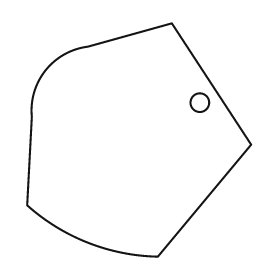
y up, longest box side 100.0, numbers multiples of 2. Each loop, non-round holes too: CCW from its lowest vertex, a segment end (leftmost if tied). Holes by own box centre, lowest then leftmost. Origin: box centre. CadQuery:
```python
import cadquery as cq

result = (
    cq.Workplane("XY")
    .moveTo(8.0, -50.0)
    .lineTo(48.0, -2.0)
    .lineTo(14.0, 50.0)
    .lineTo(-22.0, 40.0)
    .threePointArc((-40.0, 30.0), (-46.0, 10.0))
    .lineTo(-48.0, -28.0)
    .threePointArc((-22.0, -44.0), (8.0, -50.0))
    .close()
    .moveTo(26.0, 16.0)
    .circle(4.0)
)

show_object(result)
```